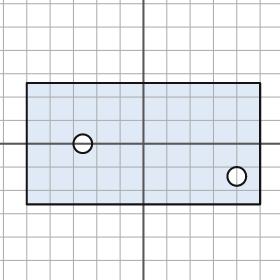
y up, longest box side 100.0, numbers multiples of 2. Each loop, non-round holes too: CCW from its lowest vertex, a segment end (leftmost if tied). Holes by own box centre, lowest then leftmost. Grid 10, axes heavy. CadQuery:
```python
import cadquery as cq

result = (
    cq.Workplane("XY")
    .moveTo(-50.0, -26.0)
    .lineTo(50.0, -26.0)
    .lineTo(50.0, 26.0)
    .lineTo(-50.0, 26.0)
    .close()
    .moveTo(40.0, -14.0)
    .circle(4.0)
    .moveTo(-26.0, 0.0)
    .circle(4.0)
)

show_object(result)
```